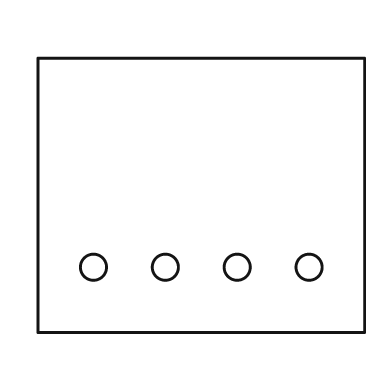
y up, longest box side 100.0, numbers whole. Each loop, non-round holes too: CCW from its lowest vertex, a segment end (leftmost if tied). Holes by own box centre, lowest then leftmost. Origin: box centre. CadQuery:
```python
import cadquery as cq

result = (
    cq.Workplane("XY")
    .moveTo(-50.0, -42.0)
    .lineTo(50.0, -42.0)
    .lineTo(50.0, 42.0)
    .lineTo(-50.0, 42.0)
    .close()
    .moveTo(-33.0, -22.0)
    .circle(4.0)
    .moveTo(-11.0, -22.0)
    .circle(4.0)
    .moveTo(11.0, -22.0)
    .circle(4.0)
    .moveTo(33.0, -22.0)
    .circle(4.0)
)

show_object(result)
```